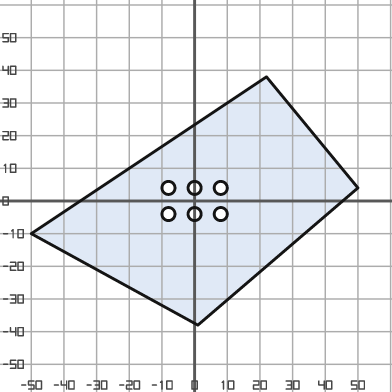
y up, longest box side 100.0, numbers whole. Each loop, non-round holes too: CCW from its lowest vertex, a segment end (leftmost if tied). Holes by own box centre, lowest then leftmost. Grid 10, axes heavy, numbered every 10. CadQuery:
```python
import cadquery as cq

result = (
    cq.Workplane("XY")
    .moveTo(1.0, -38.0)
    .lineTo(50.0, 4.0)
    .lineTo(22.0, 38.0)
    .lineTo(-50.0, -10.0)
    .close()
    .moveTo(-8.0, -4.0)
    .circle(2.0)
    .moveTo(0.0, -4.0)
    .circle(2.0)
    .moveTo(8.0, -4.0)
    .circle(2.0)
    .moveTo(-8.0, 4.0)
    .circle(2.0)
    .moveTo(0.0, 4.0)
    .circle(2.0)
    .moveTo(8.0, 4.0)
    .circle(2.0)
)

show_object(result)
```